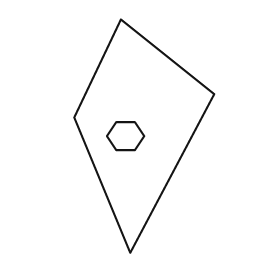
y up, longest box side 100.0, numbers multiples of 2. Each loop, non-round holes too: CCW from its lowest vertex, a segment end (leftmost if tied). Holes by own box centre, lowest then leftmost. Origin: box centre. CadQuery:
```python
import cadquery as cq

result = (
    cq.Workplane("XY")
    .moveTo(-6.0, -50.0)
    .lineTo(30.0, 18.0)
    .lineTo(-10.0, 50.0)
    .lineTo(-30.0, 8.0)
    .close()
    .moveTo(-12.0, -6.0)
    .lineTo(-4.0, -6.0)
    .lineTo(0.0, 0.0)
    .lineTo(-4.0, 6.0)
    .lineTo(-12.0, 6.0)
    .lineTo(-16.0, 0.0)
    .close()
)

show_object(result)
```